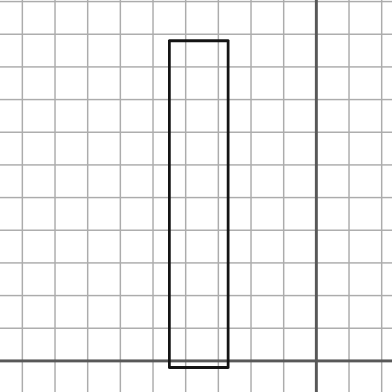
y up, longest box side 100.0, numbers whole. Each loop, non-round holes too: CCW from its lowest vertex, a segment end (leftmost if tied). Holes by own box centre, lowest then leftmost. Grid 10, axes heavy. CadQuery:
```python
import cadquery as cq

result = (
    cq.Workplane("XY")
    .moveTo(-45.0, -2.0)
    .lineTo(-27.0, -2.0)
    .lineTo(-27.0, 98.0)
    .lineTo(-45.0, 98.0)
    .close()
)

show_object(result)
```